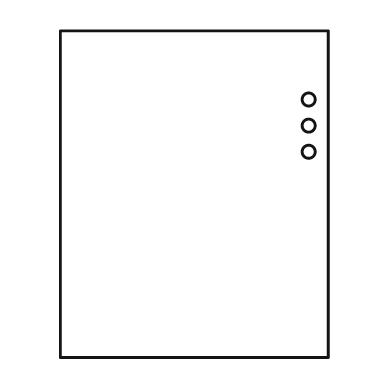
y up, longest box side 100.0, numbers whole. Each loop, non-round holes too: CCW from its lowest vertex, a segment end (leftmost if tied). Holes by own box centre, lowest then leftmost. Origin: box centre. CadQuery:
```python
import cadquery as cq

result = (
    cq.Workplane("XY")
    .moveTo(-41.0, -50.0)
    .lineTo(41.0, -50.0)
    .lineTo(41.0, 50.0)
    .lineTo(-41.0, 50.0)
    .close()
    .moveTo(35.0, 13.0)
    .circle(2.0)
    .moveTo(35.0, 21.0)
    .circle(2.0)
    .moveTo(35.0, 29.0)
    .circle(2.0)
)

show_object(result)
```